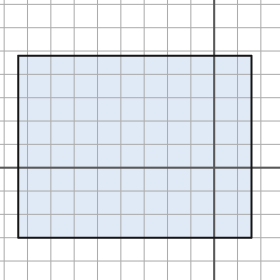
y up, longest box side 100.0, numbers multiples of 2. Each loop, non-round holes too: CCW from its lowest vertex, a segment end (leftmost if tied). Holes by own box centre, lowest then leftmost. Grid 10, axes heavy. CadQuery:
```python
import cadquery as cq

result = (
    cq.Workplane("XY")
    .moveTo(-84.0, -30.0)
    .lineTo(16.0, -30.0)
    .lineTo(16.0, 48.0)
    .lineTo(-84.0, 48.0)
    .close()
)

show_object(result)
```